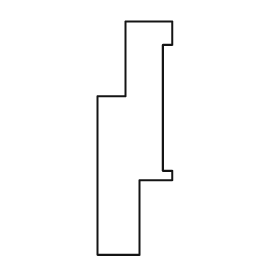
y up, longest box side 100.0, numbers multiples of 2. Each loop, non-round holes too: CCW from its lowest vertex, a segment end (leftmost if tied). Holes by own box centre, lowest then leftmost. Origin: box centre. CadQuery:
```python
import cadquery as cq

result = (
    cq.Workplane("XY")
    .moveTo(-16.0, -50.0)
    .lineTo(2.0, -50.0)
    .lineTo(2.0, -18.0)
    .lineTo(16.0, -18.0)
    .lineTo(16.0, -14.0)
    .lineTo(12.0, -14.0)
    .lineTo(12.0, 40.0)
    .lineTo(16.0, 40.0)
    .lineTo(16.0, 50.0)
    .lineTo(-4.0, 50.0)
    .lineTo(-4.0, 18.0)
    .lineTo(-16.0, 18.0)
    .close()
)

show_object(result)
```